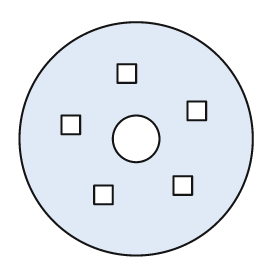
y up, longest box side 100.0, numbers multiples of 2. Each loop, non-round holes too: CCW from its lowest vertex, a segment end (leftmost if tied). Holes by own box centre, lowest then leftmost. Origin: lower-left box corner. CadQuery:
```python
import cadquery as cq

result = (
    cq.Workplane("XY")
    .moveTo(50.0, 50.0)
    .circle(50.0)
    .moveTo(32.0, 22.0)
    .lineTo(40.0, 22.0)
    .lineTo(40.0, 30.0)
    .lineTo(32.0, 30.0)
    .close()
    .moveTo(66.0, 26.0)
    .lineTo(74.0, 26.0)
    .lineTo(74.0, 34.0)
    .lineTo(66.0, 34.0)
    .close()
    .moveTo(50.0, 50.0)
    .circle(10.0)
    .moveTo(18.0, 52.0)
    .lineTo(26.0, 52.0)
    .lineTo(26.0, 60.0)
    .lineTo(18.0, 60.0)
    .close()
    .moveTo(72.0, 58.0)
    .lineTo(80.0, 58.0)
    .lineTo(80.0, 66.0)
    .lineTo(72.0, 66.0)
    .close()
    .moveTo(42.0, 74.0)
    .lineTo(50.0, 74.0)
    .lineTo(50.0, 82.0)
    .lineTo(42.0, 82.0)
    .close()
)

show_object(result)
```